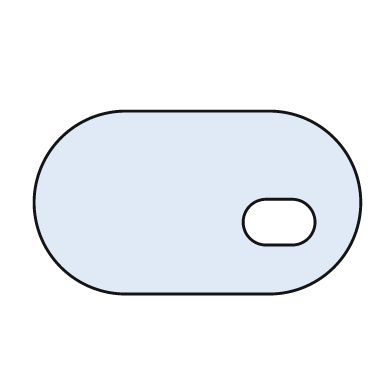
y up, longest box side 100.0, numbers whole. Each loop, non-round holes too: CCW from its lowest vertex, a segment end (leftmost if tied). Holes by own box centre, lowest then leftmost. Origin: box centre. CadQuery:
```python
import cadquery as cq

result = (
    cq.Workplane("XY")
    .moveTo(-22.0, -28.0)
    .lineTo(22.0, -28.0)
    .threePointArc((50.0, 0.0), (22.0, 28.0))
    .lineTo(-22.0, 28.0)
    .threePointArc((-50.0, 0.0), (-22.0, -28.0))
    .close()
    .moveTo(21.0, -13.0)
    .lineTo(29.0, -13.0)
    .threePointArc((36.0, -6.0), (29.0, 1.0))
    .lineTo(21.0, 1.0)
    .threePointArc((14.0, -6.0), (21.0, -13.0))
    .close()
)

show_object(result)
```